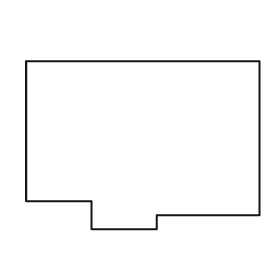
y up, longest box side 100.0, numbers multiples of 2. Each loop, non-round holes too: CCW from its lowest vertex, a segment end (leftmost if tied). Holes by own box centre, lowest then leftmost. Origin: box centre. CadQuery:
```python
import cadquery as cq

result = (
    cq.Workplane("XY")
    .moveTo(-22.0, -36.0)
    .lineTo(6.0, -36.0)
    .lineTo(6.0, -30.0)
    .lineTo(50.0, -30.0)
    .lineTo(50.0, 36.0)
    .lineTo(-50.0, 36.0)
    .lineTo(-50.0, -24.0)
    .lineTo(-22.0, -24.0)
    .close()
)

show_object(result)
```